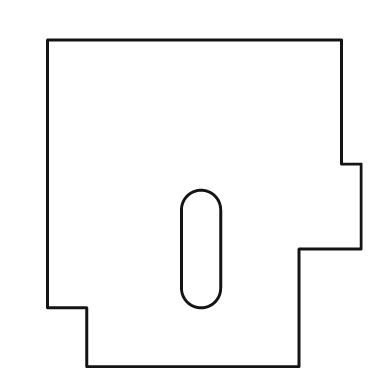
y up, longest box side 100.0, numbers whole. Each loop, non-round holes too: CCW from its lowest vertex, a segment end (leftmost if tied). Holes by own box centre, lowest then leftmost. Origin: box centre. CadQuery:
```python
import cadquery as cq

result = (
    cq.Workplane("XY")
    .moveTo(-36.0, -50.0)
    .lineTo(29.0, -50.0)
    .lineTo(29.0, -14.0)
    .lineTo(48.0, -14.0)
    .lineTo(48.0, 12.0)
    .lineTo(42.0, 12.0)
    .lineTo(42.0, 50.0)
    .lineTo(-48.0, 50.0)
    .lineTo(-48.0, -32.0)
    .lineTo(-36.0, -32.0)
    .close()
    .moveTo(-7.0, -26.0)
    .threePointArc((-1.0, -32.0), (5.0, -26.0))
    .lineTo(5.0, -2.0)
    .threePointArc((-1.0, 4.0), (-7.0, -2.0))
    .close()
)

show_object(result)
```